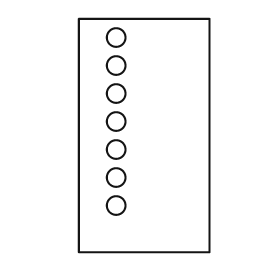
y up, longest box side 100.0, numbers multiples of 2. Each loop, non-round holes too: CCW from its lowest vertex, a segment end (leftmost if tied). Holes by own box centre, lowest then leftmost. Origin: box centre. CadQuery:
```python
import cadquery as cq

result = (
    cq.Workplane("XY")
    .moveTo(-28.0, -50.0)
    .lineTo(28.0, -50.0)
    .lineTo(28.0, 50.0)
    .lineTo(-28.0, 50.0)
    .close()
    .moveTo(-12.0, -30.0)
    .circle(4.0)
    .moveTo(-12.0, -18.0)
    .circle(4.0)
    .moveTo(-12.0, -6.0)
    .circle(4.0)
    .moveTo(-12.0, 6.0)
    .circle(4.0)
    .moveTo(-12.0, 18.0)
    .circle(4.0)
    .moveTo(-12.0, 30.0)
    .circle(4.0)
    .moveTo(-12.0, 42.0)
    .circle(4.0)
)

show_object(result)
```